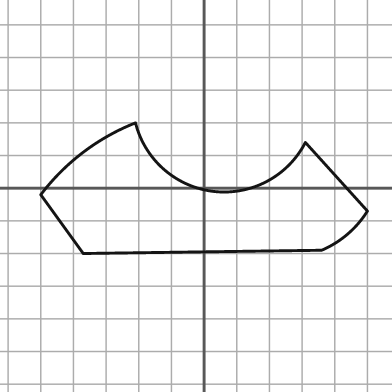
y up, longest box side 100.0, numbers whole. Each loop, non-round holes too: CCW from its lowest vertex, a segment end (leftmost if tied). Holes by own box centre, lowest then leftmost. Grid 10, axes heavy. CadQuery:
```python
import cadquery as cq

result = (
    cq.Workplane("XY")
    .moveTo(-37.0, -20.0)
    .lineTo(36.0, -19.0)
    .threePointArc((44.0, -14.0), (50.0, -7.0))
    .lineTo(31.0, 14.0)
    .threePointArc((3.0, -1.0), (-21.0, 20.0))
    .threePointArc((-37.0, 11.0), (-50.0, -2.0))
    .close()
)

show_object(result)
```